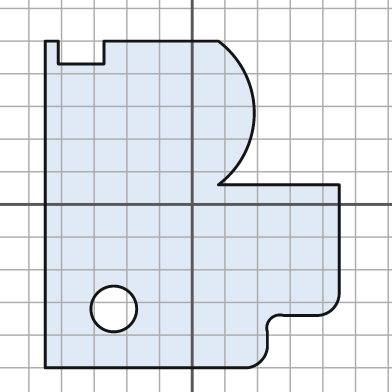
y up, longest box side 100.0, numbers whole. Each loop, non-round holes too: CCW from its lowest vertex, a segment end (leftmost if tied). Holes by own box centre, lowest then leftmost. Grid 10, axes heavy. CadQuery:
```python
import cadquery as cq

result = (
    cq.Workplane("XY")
    .moveTo(-45.0, -50.0)
    .lineTo(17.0, -50.0)
    .threePointArc((21.0, -48.0), (23.0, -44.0))
    .lineTo(23.0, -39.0)
    .threePointArc((24.0, -35.0), (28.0, -34.0))
    .lineTo(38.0, -34.0)
    .threePointArc((43.0, -32.0), (45.0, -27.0))
    .lineTo(45.0, 6.0)
    .lineTo(8.0, 6.0)
    .threePointArc((19.0, 28.0), (8.0, 50.0))
    .lineTo(-27.0, 50.0)
    .lineTo(-27.0, 43.0)
    .lineTo(-41.0, 43.0)
    .lineTo(-41.0, 50.0)
    .lineTo(-45.0, 50.0)
    .close()
    .moveTo(-24.0, -32.0)
    .circle(7.0)
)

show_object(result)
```